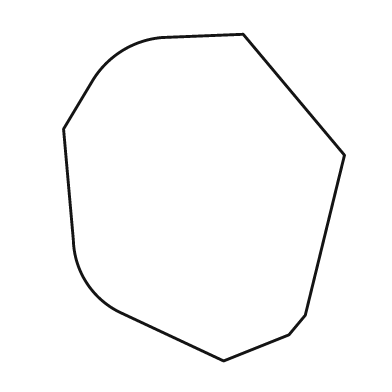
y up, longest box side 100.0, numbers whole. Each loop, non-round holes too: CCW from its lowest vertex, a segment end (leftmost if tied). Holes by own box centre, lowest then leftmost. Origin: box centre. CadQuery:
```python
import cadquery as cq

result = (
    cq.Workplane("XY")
    .moveTo(6.0, -50.0)
    .lineTo(26.0, -42.0)
    .lineTo(31.0, -36.0)
    .lineTo(43.0, 13.0)
    .lineTo(12.0, 50.0)
    .lineTo(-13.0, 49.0)
    .threePointArc((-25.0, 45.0), (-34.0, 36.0))
    .lineTo(-43.0, 21.0)
    .lineTo(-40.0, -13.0)
    .threePointArc((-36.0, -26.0), (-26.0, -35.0))
    .close()
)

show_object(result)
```